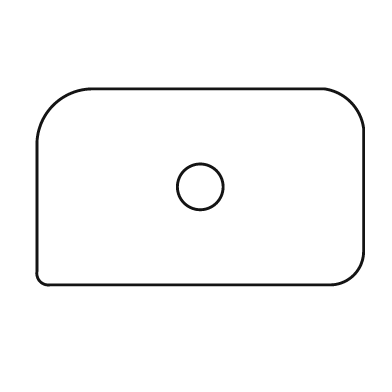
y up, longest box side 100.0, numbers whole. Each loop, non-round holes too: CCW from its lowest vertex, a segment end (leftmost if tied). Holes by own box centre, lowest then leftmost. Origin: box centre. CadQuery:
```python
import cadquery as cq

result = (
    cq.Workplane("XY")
    .moveTo(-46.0, -30.0)
    .lineTo(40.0, -30.0)
    .threePointArc((47.0, -27.0), (50.0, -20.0))
    .lineTo(50.0, 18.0)
    .threePointArc((46.0, 26.0), (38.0, 30.0))
    .lineTo(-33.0, 30.0)
    .threePointArc((-45.0, 25.0), (-50.0, 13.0))
    .lineTo(-50.0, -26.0)
    .threePointArc((-49.0, -29.0), (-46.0, -30.0))
    .close()
    .moveTo(0.0, 0.0)
    .circle(7.0)
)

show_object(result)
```